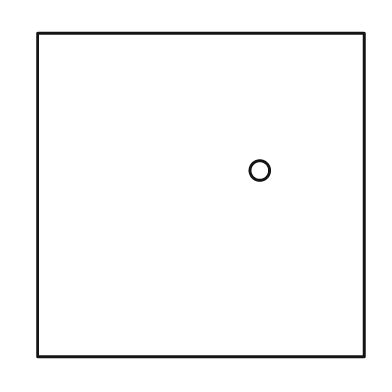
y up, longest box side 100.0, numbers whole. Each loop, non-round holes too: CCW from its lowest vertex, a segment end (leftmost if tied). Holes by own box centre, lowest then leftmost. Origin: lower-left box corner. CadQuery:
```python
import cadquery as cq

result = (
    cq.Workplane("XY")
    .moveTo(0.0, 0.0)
    .lineTo(100.0, 0.0)
    .lineTo(100.0, 99.0)
    .lineTo(0.0, 99.0)
    .close()
    .moveTo(68.0, 57.0)
    .circle(3.0)
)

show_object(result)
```